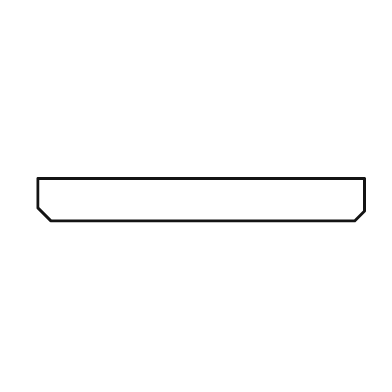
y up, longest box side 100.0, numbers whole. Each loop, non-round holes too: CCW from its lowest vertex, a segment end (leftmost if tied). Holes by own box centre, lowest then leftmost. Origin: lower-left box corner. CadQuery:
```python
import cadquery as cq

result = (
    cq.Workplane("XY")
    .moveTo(4.0, 0.0)
    .lineTo(97.0, 0.0)
    .lineTo(100.0, 3.0)
    .lineTo(100.0, 13.0)
    .lineTo(0.0, 13.0)
    .lineTo(0.0, 4.0)
    .close()
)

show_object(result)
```